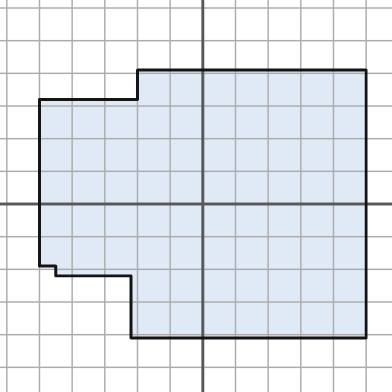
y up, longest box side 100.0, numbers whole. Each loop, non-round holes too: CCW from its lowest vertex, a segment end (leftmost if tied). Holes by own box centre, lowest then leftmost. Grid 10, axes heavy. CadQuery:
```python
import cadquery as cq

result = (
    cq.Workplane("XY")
    .moveTo(-22.0, -41.0)
    .lineTo(50.0, -41.0)
    .lineTo(50.0, 41.0)
    .lineTo(-20.0, 41.0)
    .lineTo(-20.0, 32.0)
    .lineTo(-50.0, 32.0)
    .lineTo(-50.0, -19.0)
    .lineTo(-45.0, -19.0)
    .lineTo(-45.0, -22.0)
    .lineTo(-22.0, -22.0)
    .close()
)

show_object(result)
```